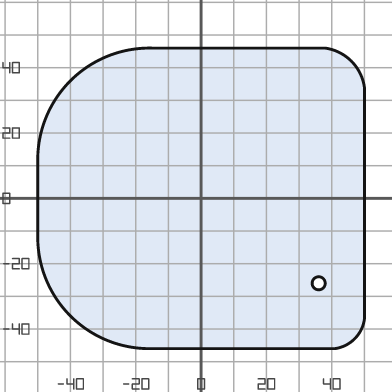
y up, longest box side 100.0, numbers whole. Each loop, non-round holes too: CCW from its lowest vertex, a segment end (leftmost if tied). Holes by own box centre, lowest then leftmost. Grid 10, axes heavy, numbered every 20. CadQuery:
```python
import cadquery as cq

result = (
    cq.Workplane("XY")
    .moveTo(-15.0, -46.0)
    .lineTo(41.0, -46.0)
    .threePointArc((47.0, -43.0), (50.0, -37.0))
    .lineTo(50.0, 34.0)
    .threePointArc((46.0, 42.0), (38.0, 46.0))
    .lineTo(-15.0, 46.0)
    .threePointArc((-40.0, 36.0), (-50.0, 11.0))
    .lineTo(-50.0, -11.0)
    .threePointArc((-40.0, -36.0), (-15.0, -46.0))
    .close()
    .moveTo(36.0, -26.0)
    .circle(2.0)
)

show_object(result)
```